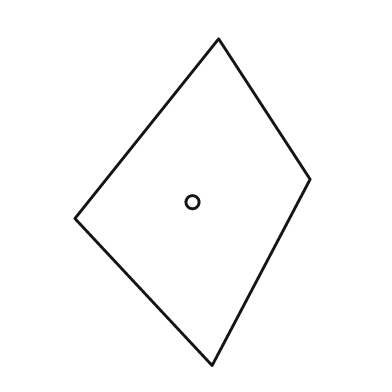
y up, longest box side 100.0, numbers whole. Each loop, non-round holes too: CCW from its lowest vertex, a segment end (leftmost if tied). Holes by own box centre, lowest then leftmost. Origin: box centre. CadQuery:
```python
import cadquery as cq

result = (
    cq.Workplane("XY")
    .moveTo(6.0, -50.0)
    .lineTo(36.0, 7.0)
    .lineTo(8.0, 50.0)
    .lineTo(-36.0, -5.0)
    .close()
    .moveTo(0.0, 0.0)
    .circle(2.0)
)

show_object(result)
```